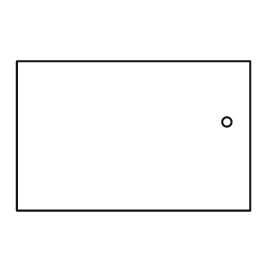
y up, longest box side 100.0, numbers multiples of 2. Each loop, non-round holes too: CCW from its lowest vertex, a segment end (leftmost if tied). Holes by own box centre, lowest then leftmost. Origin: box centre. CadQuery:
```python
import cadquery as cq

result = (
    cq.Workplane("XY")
    .moveTo(-50.0, -32.0)
    .lineTo(50.0, -32.0)
    .lineTo(50.0, 32.0)
    .lineTo(-50.0, 32.0)
    .close()
    .moveTo(40.0, 6.0)
    .circle(2.0)
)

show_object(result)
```